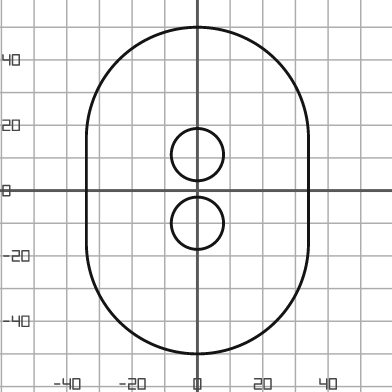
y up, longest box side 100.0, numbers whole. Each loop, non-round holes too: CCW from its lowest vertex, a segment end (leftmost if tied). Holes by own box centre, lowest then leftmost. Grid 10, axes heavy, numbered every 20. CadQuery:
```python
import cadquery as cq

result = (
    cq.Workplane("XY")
    .moveTo(-34.0, -16.0)
    .threePointArc((0.0, -50.0), (34.0, -16.0))
    .lineTo(34.0, 16.0)
    .threePointArc((0.0, 50.0), (-34.0, 16.0))
    .close()
    .moveTo(0.0, -10.0)
    .circle(8.0)
    .moveTo(0.0, 11.0)
    .circle(8.0)
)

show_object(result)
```